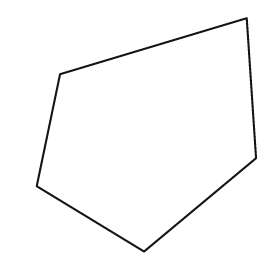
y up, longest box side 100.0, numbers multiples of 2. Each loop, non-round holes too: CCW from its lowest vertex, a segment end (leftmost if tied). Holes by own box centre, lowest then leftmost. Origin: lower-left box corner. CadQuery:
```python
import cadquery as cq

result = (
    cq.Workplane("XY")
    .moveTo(46.0, 0.0)
    .lineTo(94.0, 40.0)
    .lineTo(90.0, 100.0)
    .lineTo(10.0, 76.0)
    .lineTo(0.0, 28.0)
    .close()
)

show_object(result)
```